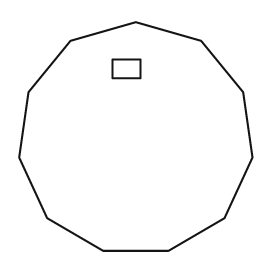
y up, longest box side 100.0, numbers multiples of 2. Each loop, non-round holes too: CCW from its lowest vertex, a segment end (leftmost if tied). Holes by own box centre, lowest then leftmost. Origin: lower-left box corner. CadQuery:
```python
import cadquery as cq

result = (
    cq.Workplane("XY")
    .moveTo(36.0, 0.0)
    .lineTo(64.0, 0.0)
    .lineTo(88.0, 14.0)
    .lineTo(100.0, 40.0)
    .lineTo(96.0, 68.0)
    .lineTo(78.0, 90.0)
    .lineTo(50.0, 98.0)
    .lineTo(22.0, 90.0)
    .lineTo(4.0, 68.0)
    .lineTo(0.0, 40.0)
    .lineTo(12.0, 14.0)
    .close()
    .moveTo(40.0, 74.0)
    .lineTo(52.0, 74.0)
    .lineTo(52.0, 82.0)
    .lineTo(40.0, 82.0)
    .close()
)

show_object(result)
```